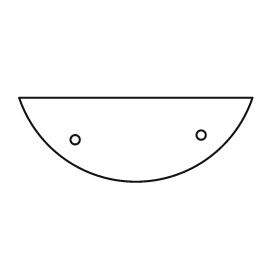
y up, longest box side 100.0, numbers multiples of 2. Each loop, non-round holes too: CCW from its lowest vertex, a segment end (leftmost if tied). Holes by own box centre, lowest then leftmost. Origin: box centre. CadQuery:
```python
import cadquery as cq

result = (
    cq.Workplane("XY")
    .moveTo(-50.0, 18.0)
    .threePointArc((0.0, -18.0), (50.0, 18.0))
    .close()
    .moveTo(-26.0, 0.0)
    .circle(2.0)
    .moveTo(28.0, 2.0)
    .circle(2.0)
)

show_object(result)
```